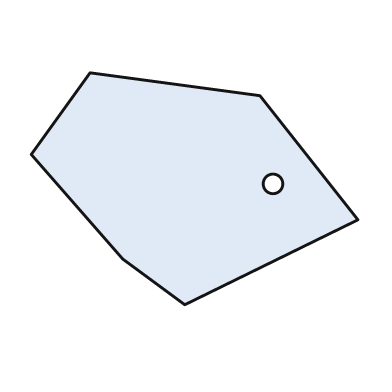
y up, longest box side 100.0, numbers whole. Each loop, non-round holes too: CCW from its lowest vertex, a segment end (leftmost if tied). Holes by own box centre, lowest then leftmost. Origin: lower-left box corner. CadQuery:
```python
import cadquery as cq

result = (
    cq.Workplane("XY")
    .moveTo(47.0, 0.0)
    .lineTo(100.0, 26.0)
    .lineTo(70.0, 64.0)
    .lineTo(18.0, 71.0)
    .lineTo(0.0, 46.0)
    .lineTo(28.0, 14.0)
    .close()
    .moveTo(74.0, 37.0)
    .circle(3.0)
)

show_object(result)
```